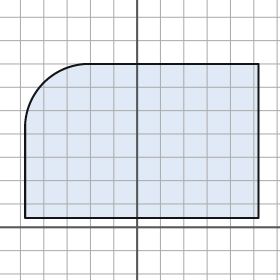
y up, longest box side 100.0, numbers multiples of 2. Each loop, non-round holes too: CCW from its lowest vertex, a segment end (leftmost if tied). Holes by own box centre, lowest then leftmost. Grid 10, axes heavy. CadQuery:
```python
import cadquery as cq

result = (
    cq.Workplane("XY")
    .moveTo(-48.0, 4.0)
    .lineTo(52.0, 4.0)
    .lineTo(52.0, 70.0)
    .lineTo(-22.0, 70.0)
    .threePointArc((-40.0, 62.0), (-48.0, 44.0))
    .close()
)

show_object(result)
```